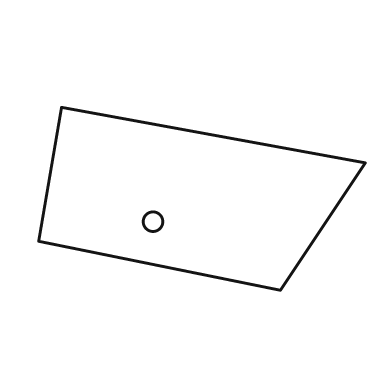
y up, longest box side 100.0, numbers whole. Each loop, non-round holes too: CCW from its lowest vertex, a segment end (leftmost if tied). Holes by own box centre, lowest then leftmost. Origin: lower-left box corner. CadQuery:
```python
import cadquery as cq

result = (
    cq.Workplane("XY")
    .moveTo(74.0, 0.0)
    .lineTo(100.0, 39.0)
    .lineTo(7.0, 56.0)
    .lineTo(0.0, 15.0)
    .close()
    .moveTo(35.0, 21.0)
    .circle(3.0)
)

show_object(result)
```